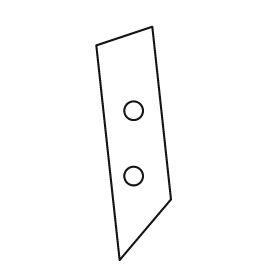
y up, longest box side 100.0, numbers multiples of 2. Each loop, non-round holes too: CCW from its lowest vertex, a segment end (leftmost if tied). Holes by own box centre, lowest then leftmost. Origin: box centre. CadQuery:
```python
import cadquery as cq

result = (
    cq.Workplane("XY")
    .moveTo(-6.0, -50.0)
    .lineTo(16.0, -24.0)
    .lineTo(8.0, 50.0)
    .lineTo(-16.0, 42.0)
    .close()
    .moveTo(0.0, -14.0)
    .circle(4.0)
    .moveTo(0.0, 14.0)
    .circle(4.0)
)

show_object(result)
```